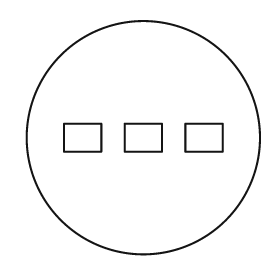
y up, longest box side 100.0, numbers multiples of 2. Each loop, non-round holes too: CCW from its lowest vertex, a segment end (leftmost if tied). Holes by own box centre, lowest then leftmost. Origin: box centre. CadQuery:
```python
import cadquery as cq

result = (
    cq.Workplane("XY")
    .moveTo(0.0, 0.0)
    .circle(50.0)
    .moveTo(-34.0, -6.0)
    .lineTo(-18.0, -6.0)
    .lineTo(-18.0, 6.0)
    .lineTo(-34.0, 6.0)
    .close()
    .moveTo(-8.0, -6.0)
    .lineTo(8.0, -6.0)
    .lineTo(8.0, 6.0)
    .lineTo(-8.0, 6.0)
    .close()
    .moveTo(18.0, -6.0)
    .lineTo(34.0, -6.0)
    .lineTo(34.0, 6.0)
    .lineTo(18.0, 6.0)
    .close()
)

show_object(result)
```